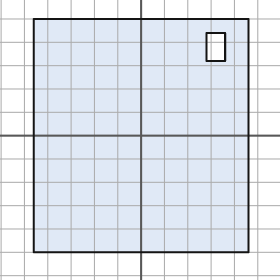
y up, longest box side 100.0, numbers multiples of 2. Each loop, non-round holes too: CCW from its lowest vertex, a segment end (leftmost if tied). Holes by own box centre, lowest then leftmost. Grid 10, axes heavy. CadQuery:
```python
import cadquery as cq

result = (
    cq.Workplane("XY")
    .moveTo(-46.0, -50.0)
    .lineTo(46.0, -50.0)
    .lineTo(46.0, 50.0)
    .lineTo(-46.0, 50.0)
    .close()
    .moveTo(28.0, 32.0)
    .lineTo(36.0, 32.0)
    .lineTo(36.0, 44.0)
    .lineTo(28.0, 44.0)
    .close()
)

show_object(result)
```